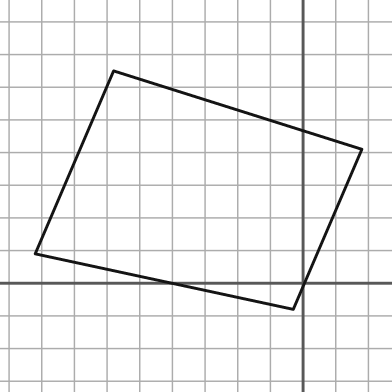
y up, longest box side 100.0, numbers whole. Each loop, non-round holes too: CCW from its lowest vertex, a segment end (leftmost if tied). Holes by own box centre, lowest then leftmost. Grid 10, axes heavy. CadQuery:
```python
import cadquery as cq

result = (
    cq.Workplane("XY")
    .moveTo(-3.0, -8.0)
    .lineTo(18.0, 41.0)
    .lineTo(-58.0, 65.0)
    .lineTo(-82.0, 9.0)
    .close()
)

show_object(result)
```